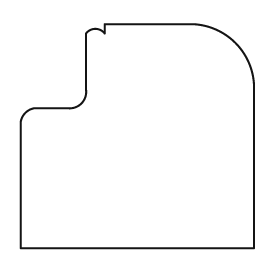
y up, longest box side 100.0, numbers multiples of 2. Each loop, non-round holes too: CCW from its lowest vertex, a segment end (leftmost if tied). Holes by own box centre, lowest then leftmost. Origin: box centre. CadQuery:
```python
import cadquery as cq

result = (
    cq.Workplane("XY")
    .moveTo(-50.0, -48.0)
    .lineTo(50.0, -48.0)
    .lineTo(50.0, 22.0)
    .threePointArc((42.0, 40.0), (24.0, 48.0))
    .lineTo(-14.0, 48.0)
    .lineTo(-14.0, 44.0)
    .threePointArc((-18.0, 46.0), (-22.0, 44.0))
    .lineTo(-22.0, 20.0)
    .threePointArc((-24.0, 14.0), (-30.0, 12.0))
    .lineTo(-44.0, 12.0)
    .threePointArc((-48.0, 10.0), (-50.0, 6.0))
    .close()
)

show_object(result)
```